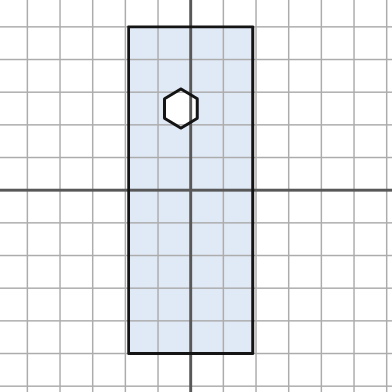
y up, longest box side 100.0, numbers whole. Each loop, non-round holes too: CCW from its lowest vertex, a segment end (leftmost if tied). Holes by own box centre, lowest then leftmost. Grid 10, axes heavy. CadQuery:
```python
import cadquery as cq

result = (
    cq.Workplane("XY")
    .moveTo(-19.0, -50.0)
    .lineTo(19.0, -50.0)
    .lineTo(19.0, 50.0)
    .lineTo(-19.0, 50.0)
    .close()
    .moveTo(-3.0, 19.0)
    .lineTo(2.0, 22.0)
    .lineTo(2.0, 28.0)
    .lineTo(-3.0, 31.0)
    .lineTo(-8.0, 28.0)
    .lineTo(-8.0, 22.0)
    .close()
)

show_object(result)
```